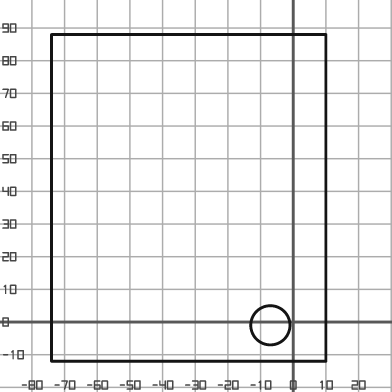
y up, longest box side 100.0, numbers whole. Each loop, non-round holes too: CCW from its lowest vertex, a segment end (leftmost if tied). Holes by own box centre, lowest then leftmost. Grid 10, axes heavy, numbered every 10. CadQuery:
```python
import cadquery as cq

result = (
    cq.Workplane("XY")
    .moveTo(-74.0, -12.0)
    .lineTo(10.0, -12.0)
    .lineTo(10.0, 88.0)
    .lineTo(-74.0, 88.0)
    .close()
    .moveTo(-7.0, -1.0)
    .circle(6.0)
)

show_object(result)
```